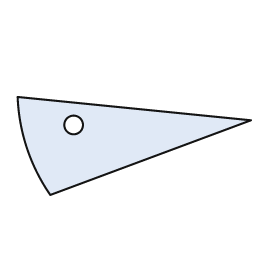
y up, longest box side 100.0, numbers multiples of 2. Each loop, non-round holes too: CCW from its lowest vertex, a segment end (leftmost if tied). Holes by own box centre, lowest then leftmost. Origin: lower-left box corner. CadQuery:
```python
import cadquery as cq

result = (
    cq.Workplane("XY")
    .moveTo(14.0, 0.0)
    .lineTo(100.0, 32.0)
    .lineTo(0.0, 42.0)
    .threePointArc((4.0, 20.0), (14.0, 0.0))
    .close()
    .moveTo(24.0, 30.0)
    .circle(4.0)
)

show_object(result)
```